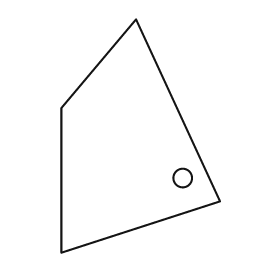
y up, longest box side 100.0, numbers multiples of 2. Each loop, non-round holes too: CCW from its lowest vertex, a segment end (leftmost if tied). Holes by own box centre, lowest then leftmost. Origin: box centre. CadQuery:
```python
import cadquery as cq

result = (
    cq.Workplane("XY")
    .moveTo(-34.0, -50.0)
    .lineTo(34.0, -28.0)
    .lineTo(-2.0, 50.0)
    .lineTo(-34.0, 12.0)
    .close()
    .moveTo(18.0, -18.0)
    .circle(4.0)
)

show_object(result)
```